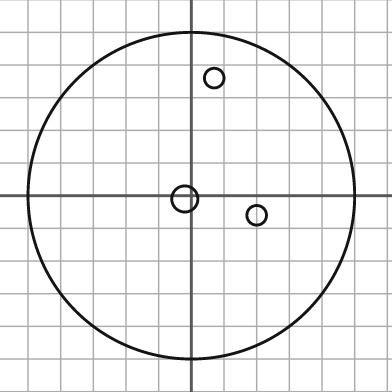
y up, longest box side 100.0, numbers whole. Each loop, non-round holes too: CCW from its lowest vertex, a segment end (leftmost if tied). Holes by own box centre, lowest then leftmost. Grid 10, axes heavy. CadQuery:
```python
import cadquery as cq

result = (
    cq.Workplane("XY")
    .moveTo(0.0, 0.0)
    .circle(50.0)
    .moveTo(20.0, -6.0)
    .circle(3.0)
    .moveTo(-2.0, -1.0)
    .circle(4.0)
    .moveTo(7.0, 36.0)
    .circle(3.0)
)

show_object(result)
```